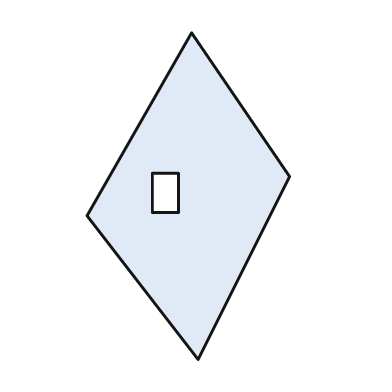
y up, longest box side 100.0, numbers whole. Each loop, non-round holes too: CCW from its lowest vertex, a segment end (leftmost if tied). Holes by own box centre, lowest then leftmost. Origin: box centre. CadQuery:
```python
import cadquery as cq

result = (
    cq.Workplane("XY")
    .moveTo(3.0, -50.0)
    .lineTo(31.0, 6.0)
    .lineTo(1.0, 50.0)
    .lineTo(-31.0, -6.0)
    .close()
    .moveTo(-11.0, -5.0)
    .lineTo(-3.0, -5.0)
    .lineTo(-3.0, 7.0)
    .lineTo(-11.0, 7.0)
    .close()
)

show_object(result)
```